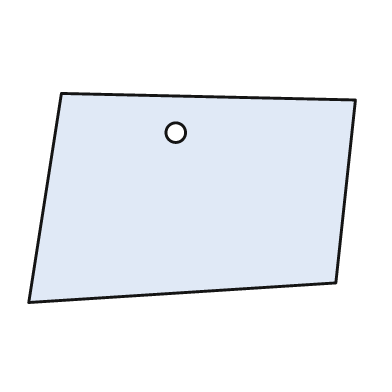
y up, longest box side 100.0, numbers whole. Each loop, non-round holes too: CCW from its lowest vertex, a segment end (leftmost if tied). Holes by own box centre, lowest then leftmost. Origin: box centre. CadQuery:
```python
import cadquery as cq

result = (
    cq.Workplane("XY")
    .moveTo(-50.0, -32.0)
    .lineTo(44.0, -26.0)
    .lineTo(50.0, 30.0)
    .lineTo(-40.0, 32.0)
    .close()
    .moveTo(-5.0, 20.0)
    .circle(3.0)
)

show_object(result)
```